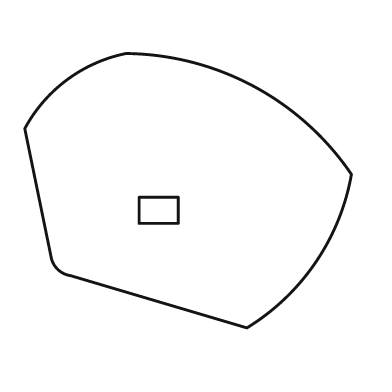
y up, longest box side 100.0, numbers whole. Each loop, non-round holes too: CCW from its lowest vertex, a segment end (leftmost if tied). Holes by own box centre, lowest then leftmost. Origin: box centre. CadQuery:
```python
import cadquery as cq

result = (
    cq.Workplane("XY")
    .moveTo(18.0, -42.0)
    .threePointArc((39.0, -22.0), (50.0, 5.0))
    .threePointArc((20.0, 32.0), (-19.0, 42.0))
    .threePointArc((-37.0, 34.0), (-50.0, 19.0))
    .lineTo(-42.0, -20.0)
    .threePointArc((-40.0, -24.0), (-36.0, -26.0))
    .close()
    .moveTo(-15.0, -10.0)
    .lineTo(-3.0, -10.0)
    .lineTo(-3.0, -2.0)
    .lineTo(-15.0, -2.0)
    .close()
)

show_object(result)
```